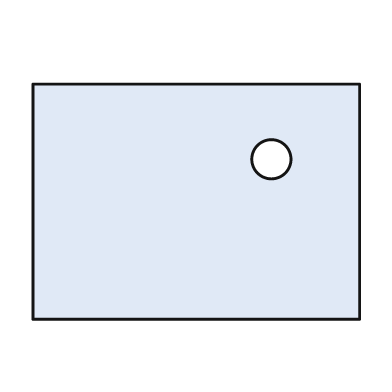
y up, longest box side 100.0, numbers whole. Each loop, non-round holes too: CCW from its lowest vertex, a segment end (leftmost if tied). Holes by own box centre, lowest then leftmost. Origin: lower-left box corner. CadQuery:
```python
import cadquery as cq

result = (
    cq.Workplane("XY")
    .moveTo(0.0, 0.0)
    .lineTo(100.0, 0.0)
    .lineTo(100.0, 72.0)
    .lineTo(0.0, 72.0)
    .close()
    .moveTo(73.0, 49.0)
    .circle(6.0)
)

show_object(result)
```